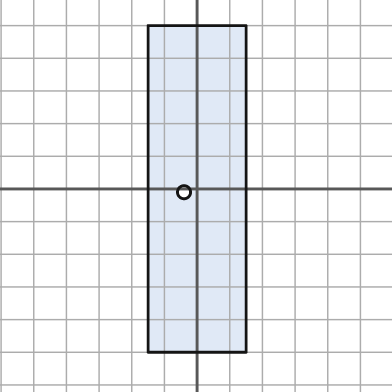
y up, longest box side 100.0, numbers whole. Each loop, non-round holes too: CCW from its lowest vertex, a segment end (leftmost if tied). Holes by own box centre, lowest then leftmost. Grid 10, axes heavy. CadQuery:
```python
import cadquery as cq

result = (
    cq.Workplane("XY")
    .moveTo(-15.0, -50.0)
    .lineTo(15.0, -50.0)
    .lineTo(15.0, 50.0)
    .lineTo(-15.0, 50.0)
    .close()
    .moveTo(-4.0, -1.0)
    .circle(2.0)
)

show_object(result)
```